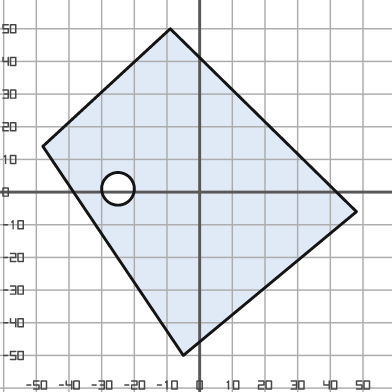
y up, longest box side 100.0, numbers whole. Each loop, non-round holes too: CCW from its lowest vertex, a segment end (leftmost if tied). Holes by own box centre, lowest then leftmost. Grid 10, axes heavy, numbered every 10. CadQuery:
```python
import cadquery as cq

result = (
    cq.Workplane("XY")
    .moveTo(-5.0, -50.0)
    .lineTo(48.0, -6.0)
    .lineTo(-9.0, 50.0)
    .lineTo(-48.0, 14.0)
    .close()
    .moveTo(-25.0, 1.0)
    .circle(5.0)
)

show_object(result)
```